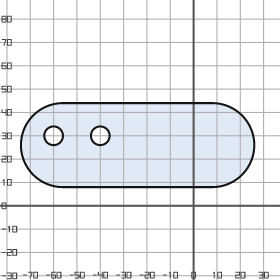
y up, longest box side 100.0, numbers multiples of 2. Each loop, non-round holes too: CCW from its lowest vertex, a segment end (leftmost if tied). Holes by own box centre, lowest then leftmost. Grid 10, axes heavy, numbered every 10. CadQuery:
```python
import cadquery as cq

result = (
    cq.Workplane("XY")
    .moveTo(-56.0, 8.0)
    .lineTo(8.0, 8.0)
    .threePointArc((26.0, 26.0), (8.0, 44.0))
    .lineTo(-56.0, 44.0)
    .threePointArc((-74.0, 26.0), (-56.0, 8.0))
    .close()
    .moveTo(-60.0, 30.0)
    .circle(4.0)
    .moveTo(-40.0, 30.0)
    .circle(4.0)
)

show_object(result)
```